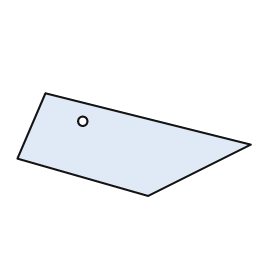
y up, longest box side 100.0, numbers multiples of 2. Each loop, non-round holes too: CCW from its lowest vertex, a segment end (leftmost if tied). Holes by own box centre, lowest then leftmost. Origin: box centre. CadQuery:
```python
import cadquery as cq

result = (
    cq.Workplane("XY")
    .moveTo(6.0, -22.0)
    .lineTo(50.0, 0.0)
    .lineTo(-38.0, 22.0)
    .lineTo(-50.0, -6.0)
    .close()
    .moveTo(-22.0, 10.0)
    .circle(2.0)
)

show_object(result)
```